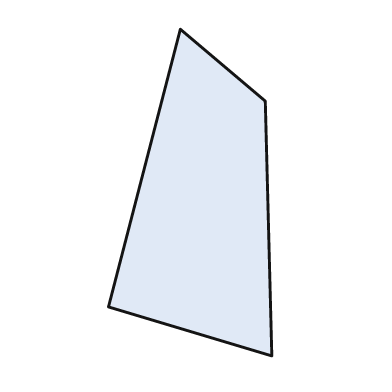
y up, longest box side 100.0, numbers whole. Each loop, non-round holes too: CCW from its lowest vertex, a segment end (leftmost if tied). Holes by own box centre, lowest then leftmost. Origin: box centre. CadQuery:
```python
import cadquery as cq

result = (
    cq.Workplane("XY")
    .moveTo(25.0, -50.0)
    .lineTo(23.0, 28.0)
    .lineTo(-3.0, 50.0)
    .lineTo(-25.0, -35.0)
    .close()
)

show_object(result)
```